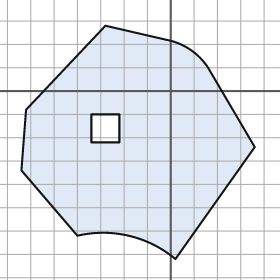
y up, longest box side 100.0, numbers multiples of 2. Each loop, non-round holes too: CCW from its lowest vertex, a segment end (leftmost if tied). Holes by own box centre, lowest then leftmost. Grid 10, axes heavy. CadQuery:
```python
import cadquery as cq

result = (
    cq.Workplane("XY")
    .moveTo(2.0, -72.0)
    .lineTo(36.0, -24.0)
    .lineTo(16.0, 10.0)
    .threePointArc((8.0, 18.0), (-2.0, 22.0))
    .lineTo(-28.0, 28.0)
    .lineTo(-62.0, -8.0)
    .lineTo(-64.0, -34.0)
    .lineTo(-40.0, -62.0)
    .threePointArc((-18.0, -62.0), (2.0, -72.0))
    .close()
    .moveTo(-34.0, -22.0)
    .lineTo(-22.0, -22.0)
    .lineTo(-22.0, -10.0)
    .lineTo(-34.0, -10.0)
    .close()
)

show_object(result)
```